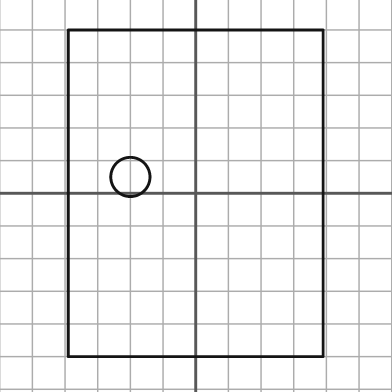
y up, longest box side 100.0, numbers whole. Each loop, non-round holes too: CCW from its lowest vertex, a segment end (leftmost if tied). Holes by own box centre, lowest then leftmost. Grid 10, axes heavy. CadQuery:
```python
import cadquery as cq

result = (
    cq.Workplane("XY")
    .moveTo(-39.0, -50.0)
    .lineTo(39.0, -50.0)
    .lineTo(39.0, 50.0)
    .lineTo(-39.0, 50.0)
    .close()
    .moveTo(-20.0, 5.0)
    .circle(6.0)
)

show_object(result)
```